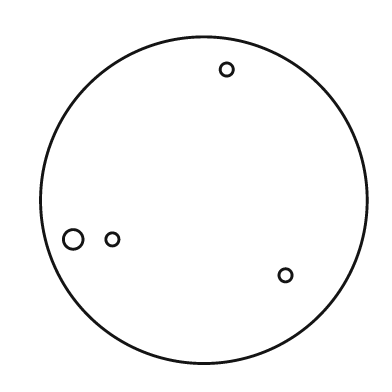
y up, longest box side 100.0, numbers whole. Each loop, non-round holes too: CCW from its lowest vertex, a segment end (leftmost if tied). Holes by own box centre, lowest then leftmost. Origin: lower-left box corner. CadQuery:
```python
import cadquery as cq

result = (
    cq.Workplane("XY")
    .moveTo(50.0, 50.0)
    .circle(50.0)
    .moveTo(75.0, 27.0)
    .circle(2.0)
    .moveTo(10.0, 38.0)
    .circle(3.0)
    .moveTo(22.0, 38.0)
    .circle(2.0)
    .moveTo(57.0, 90.0)
    .circle(2.0)
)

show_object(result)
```